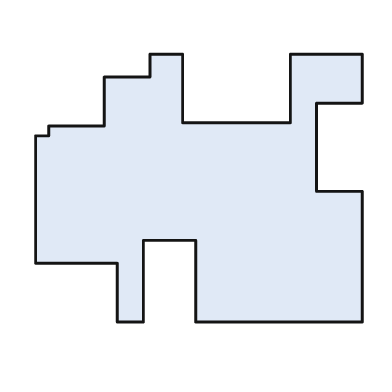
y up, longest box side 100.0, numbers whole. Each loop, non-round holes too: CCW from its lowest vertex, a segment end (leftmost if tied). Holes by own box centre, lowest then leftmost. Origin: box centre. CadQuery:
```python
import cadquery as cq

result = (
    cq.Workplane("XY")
    .moveTo(-25.0, -41.0)
    .lineTo(-17.0, -41.0)
    .lineTo(-17.0, -16.0)
    .lineTo(-1.0, -16.0)
    .lineTo(-1.0, -41.0)
    .lineTo(50.0, -41.0)
    .lineTo(50.0, -1.0)
    .lineTo(36.0, -1.0)
    .lineTo(36.0, 26.0)
    .lineTo(50.0, 26.0)
    .lineTo(50.0, 41.0)
    .lineTo(28.0, 41.0)
    .lineTo(28.0, 20.0)
    .lineTo(-5.0, 20.0)
    .lineTo(-5.0, 41.0)
    .lineTo(-15.0, 41.0)
    .lineTo(-15.0, 34.0)
    .lineTo(-29.0, 34.0)
    .lineTo(-29.0, 19.0)
    .lineTo(-46.0, 19.0)
    .lineTo(-46.0, 16.0)
    .lineTo(-50.0, 16.0)
    .lineTo(-50.0, -23.0)
    .lineTo(-25.0, -23.0)
    .close()
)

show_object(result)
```